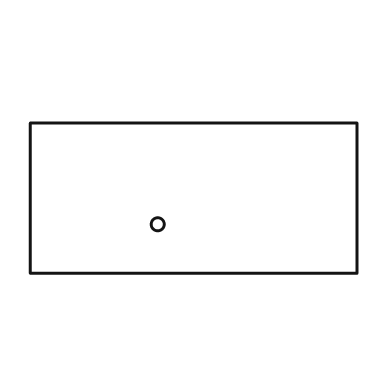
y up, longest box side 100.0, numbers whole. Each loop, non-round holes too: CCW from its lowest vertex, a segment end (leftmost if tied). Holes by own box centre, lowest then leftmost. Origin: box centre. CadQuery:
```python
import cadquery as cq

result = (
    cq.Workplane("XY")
    .moveTo(-50.0, -23.0)
    .lineTo(50.0, -23.0)
    .lineTo(50.0, 23.0)
    .lineTo(-50.0, 23.0)
    .close()
    .moveTo(-11.0, -8.0)
    .circle(2.0)
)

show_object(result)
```